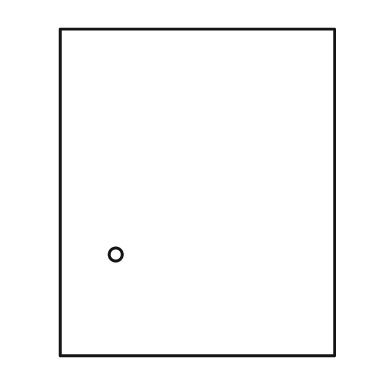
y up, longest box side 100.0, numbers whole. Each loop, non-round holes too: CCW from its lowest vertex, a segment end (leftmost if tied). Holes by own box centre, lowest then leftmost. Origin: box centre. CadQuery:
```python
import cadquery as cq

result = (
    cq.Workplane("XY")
    .moveTo(-42.0, -50.0)
    .lineTo(42.0, -50.0)
    .lineTo(42.0, 50.0)
    .lineTo(-42.0, 50.0)
    .close()
    .moveTo(-25.0, -19.0)
    .circle(2.0)
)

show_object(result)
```